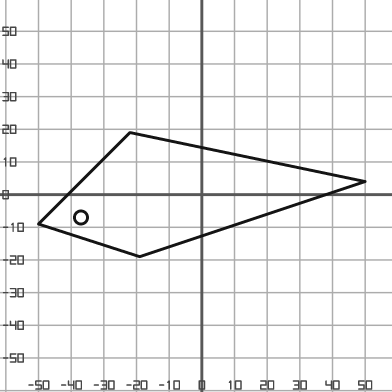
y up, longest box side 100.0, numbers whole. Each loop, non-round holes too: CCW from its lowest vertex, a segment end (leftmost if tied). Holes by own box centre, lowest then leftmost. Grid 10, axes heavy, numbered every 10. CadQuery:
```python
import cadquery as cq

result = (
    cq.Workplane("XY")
    .moveTo(-19.0, -19.0)
    .lineTo(50.0, 4.0)
    .lineTo(-22.0, 19.0)
    .lineTo(-50.0, -9.0)
    .close()
    .moveTo(-37.0, -7.0)
    .circle(2.0)
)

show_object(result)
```